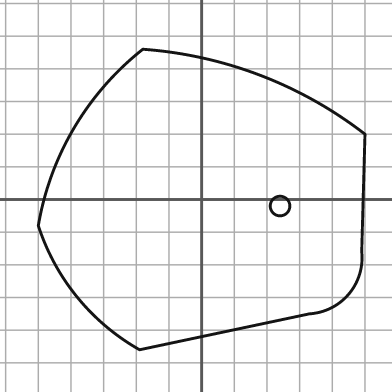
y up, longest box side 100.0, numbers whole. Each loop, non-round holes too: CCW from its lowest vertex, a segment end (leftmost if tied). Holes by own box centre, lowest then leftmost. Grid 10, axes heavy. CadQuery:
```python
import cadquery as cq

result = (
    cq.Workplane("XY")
    .moveTo(-19.0, -46.0)
    .lineTo(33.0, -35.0)
    .threePointArc((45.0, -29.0), (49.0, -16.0))
    .lineTo(50.0, 20.0)
    .threePointArc((18.0, 38.0), (-18.0, 46.0))
    .threePointArc((-39.0, 22.0), (-50.0, -8.0))
    .threePointArc((-38.0, -30.0), (-19.0, -46.0))
    .close()
    .moveTo(24.0, -2.0)
    .circle(3.0)
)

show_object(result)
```